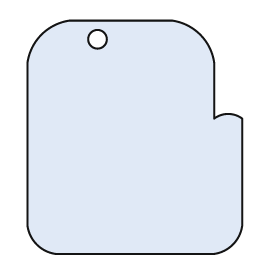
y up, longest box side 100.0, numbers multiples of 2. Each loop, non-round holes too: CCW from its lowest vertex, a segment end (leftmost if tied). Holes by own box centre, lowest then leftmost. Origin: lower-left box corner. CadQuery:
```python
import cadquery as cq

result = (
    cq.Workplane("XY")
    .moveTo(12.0, 0.0)
    .lineTo(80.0, 0.0)
    .threePointArc((88.0, 4.0), (92.0, 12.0))
    .lineTo(92.0, 58.0)
    .threePointArc((86.0, 60.0), (80.0, 58.0))
    .lineTo(80.0, 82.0)
    .threePointArc((74.0, 94.0), (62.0, 100.0))
    .lineTo(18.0, 100.0)
    .threePointArc((6.0, 94.0), (0.0, 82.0))
    .lineTo(0.0, 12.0)
    .threePointArc((4.0, 4.0), (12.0, 0.0))
    .close()
    .moveTo(30.0, 92.0)
    .circle(4.0)
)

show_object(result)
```